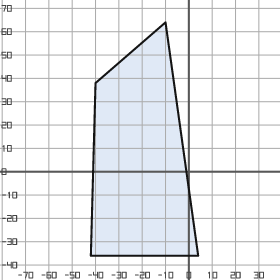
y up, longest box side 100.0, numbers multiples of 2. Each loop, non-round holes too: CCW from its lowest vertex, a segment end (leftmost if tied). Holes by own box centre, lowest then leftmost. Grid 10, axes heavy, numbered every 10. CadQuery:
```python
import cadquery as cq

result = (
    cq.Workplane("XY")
    .moveTo(-42.0, -36.0)
    .lineTo(4.0, -36.0)
    .lineTo(-10.0, 64.0)
    .lineTo(-40.0, 38.0)
    .close()
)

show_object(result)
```